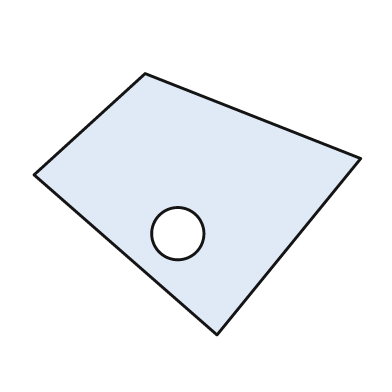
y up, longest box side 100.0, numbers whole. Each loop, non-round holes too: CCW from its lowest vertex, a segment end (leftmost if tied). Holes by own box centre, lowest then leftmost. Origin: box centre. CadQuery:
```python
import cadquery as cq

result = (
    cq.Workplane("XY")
    .moveTo(6.0, -40.0)
    .lineTo(50.0, 14.0)
    .lineTo(-16.0, 40.0)
    .lineTo(-50.0, 9.0)
    .close()
    .moveTo(-6.0, -9.0)
    .circle(8.0)
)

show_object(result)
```